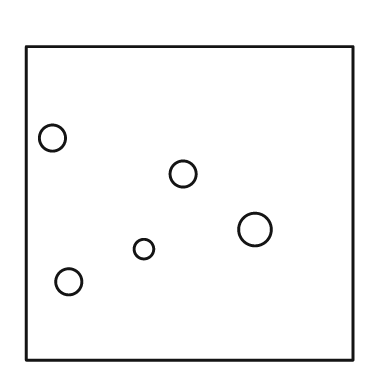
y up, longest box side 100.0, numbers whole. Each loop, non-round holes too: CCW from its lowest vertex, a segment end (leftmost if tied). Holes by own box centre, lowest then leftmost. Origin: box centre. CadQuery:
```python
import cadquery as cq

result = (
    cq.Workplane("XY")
    .moveTo(-50.0, -48.0)
    .lineTo(50.0, -48.0)
    .lineTo(50.0, 48.0)
    .lineTo(-50.0, 48.0)
    .close()
    .moveTo(-37.0, -24.0)
    .circle(4.0)
    .moveTo(-14.0, -14.0)
    .circle(3.0)
    .moveTo(20.0, -8.0)
    .circle(5.0)
    .moveTo(-2.0, 9.0)
    .circle(4.0)
    .moveTo(-42.0, 20.0)
    .circle(4.0)
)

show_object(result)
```